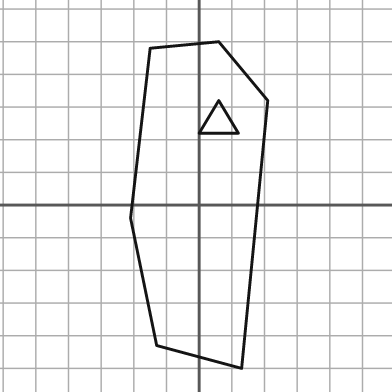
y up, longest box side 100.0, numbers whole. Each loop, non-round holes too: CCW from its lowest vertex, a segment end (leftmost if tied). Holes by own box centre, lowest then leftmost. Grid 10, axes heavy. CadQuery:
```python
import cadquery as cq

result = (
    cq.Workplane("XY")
    .moveTo(13.0, -50.0)
    .lineTo(21.0, 32.0)
    .lineTo(6.0, 50.0)
    .lineTo(-15.0, 48.0)
    .lineTo(-21.0, -4.0)
    .lineTo(-13.0, -43.0)
    .close()
    .moveTo(0.0, 22.0)
    .lineTo(12.0, 22.0)
    .lineTo(6.0, 32.0)
    .close()
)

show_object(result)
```